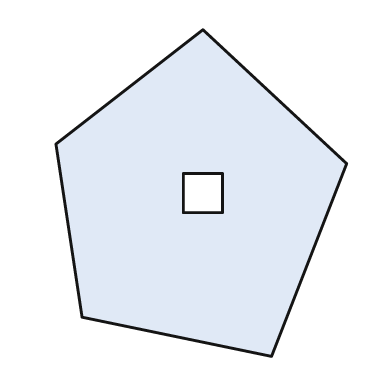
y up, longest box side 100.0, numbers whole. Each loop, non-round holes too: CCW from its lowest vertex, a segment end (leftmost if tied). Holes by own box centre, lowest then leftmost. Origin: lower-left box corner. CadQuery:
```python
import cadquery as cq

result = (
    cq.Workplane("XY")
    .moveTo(66.0, 0.0)
    .lineTo(89.0, 59.0)
    .lineTo(45.0, 100.0)
    .lineTo(0.0, 65.0)
    .lineTo(8.0, 12.0)
    .close()
    .moveTo(39.0, 44.0)
    .lineTo(51.0, 44.0)
    .lineTo(51.0, 56.0)
    .lineTo(39.0, 56.0)
    .close()
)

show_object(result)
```